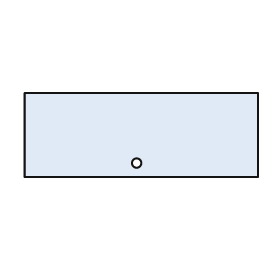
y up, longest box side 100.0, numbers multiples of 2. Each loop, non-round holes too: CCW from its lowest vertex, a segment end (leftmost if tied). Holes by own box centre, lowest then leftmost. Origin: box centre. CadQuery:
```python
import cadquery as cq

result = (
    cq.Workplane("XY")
    .moveTo(-50.0, -18.0)
    .lineTo(50.0, -18.0)
    .lineTo(50.0, 18.0)
    .lineTo(-50.0, 18.0)
    .close()
    .moveTo(-2.0, -12.0)
    .circle(2.0)
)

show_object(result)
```